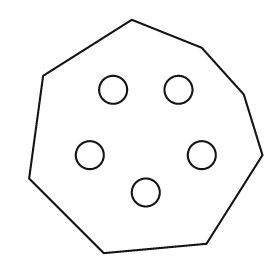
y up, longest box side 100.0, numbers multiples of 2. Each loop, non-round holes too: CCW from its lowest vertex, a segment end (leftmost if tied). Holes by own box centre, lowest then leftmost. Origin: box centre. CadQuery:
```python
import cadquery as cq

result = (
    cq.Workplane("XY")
    .moveTo(-18.0, -50.0)
    .lineTo(26.0, -46.0)
    .lineTo(50.0, -8.0)
    .lineTo(42.0, 18.0)
    .lineTo(24.0, 38.0)
    .lineTo(-6.0, 50.0)
    .lineTo(-44.0, 26.0)
    .lineTo(-50.0, -18.0)
    .close()
    .moveTo(0.0, -24.0)
    .circle(6.0)
    .moveTo(-24.0, -8.0)
    .circle(6.0)
    .moveTo(24.0, -8.0)
    .circle(6.0)
    .moveTo(-14.0, 20.0)
    .circle(6.0)
    .moveTo(14.0, 20.0)
    .circle(6.0)
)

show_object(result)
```